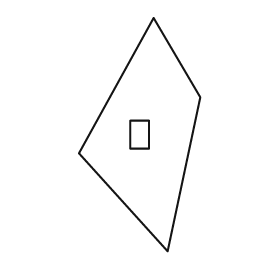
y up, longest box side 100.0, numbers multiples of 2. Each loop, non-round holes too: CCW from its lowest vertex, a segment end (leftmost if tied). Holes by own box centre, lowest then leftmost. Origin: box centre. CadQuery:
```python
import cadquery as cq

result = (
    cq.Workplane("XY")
    .moveTo(12.0, -50.0)
    .lineTo(26.0, 16.0)
    .lineTo(6.0, 50.0)
    .lineTo(-26.0, -8.0)
    .close()
    .moveTo(-4.0, -6.0)
    .lineTo(4.0, -6.0)
    .lineTo(4.0, 6.0)
    .lineTo(-4.0, 6.0)
    .close()
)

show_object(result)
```